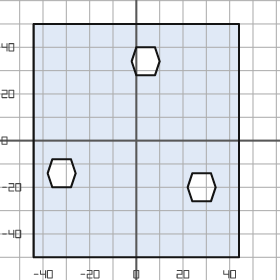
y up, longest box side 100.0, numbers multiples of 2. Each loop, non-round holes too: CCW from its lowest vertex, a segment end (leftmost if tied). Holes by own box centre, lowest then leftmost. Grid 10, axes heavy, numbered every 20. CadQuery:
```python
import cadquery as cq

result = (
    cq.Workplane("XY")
    .moveTo(-44.0, -50.0)
    .lineTo(44.0, -50.0)
    .lineTo(44.0, 50.0)
    .lineTo(-44.0, 50.0)
    .close()
    .moveTo(24.0, -26.0)
    .lineTo(32.0, -26.0)
    .lineTo(34.0, -20.0)
    .lineTo(32.0, -14.0)
    .lineTo(24.0, -14.0)
    .lineTo(22.0, -20.0)
    .close()
    .moveTo(-36.0, -20.0)
    .lineTo(-28.0, -20.0)
    .lineTo(-26.0, -14.0)
    .lineTo(-28.0, -8.0)
    .lineTo(-36.0, -8.0)
    .lineTo(-38.0, -14.0)
    .close()
    .moveTo(0.0, 28.0)
    .lineTo(8.0, 28.0)
    .lineTo(10.0, 34.0)
    .lineTo(8.0, 40.0)
    .lineTo(0.0, 40.0)
    .lineTo(-2.0, 34.0)
    .close()
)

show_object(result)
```